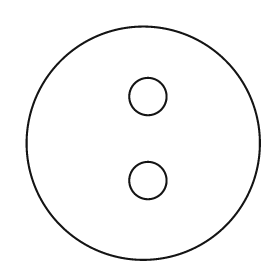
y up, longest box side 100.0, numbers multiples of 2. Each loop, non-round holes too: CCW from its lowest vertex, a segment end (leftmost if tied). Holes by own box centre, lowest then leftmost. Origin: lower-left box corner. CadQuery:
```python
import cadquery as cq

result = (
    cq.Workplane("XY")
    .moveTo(50.0, 50.0)
    .circle(50.0)
    .moveTo(52.0, 34.0)
    .circle(8.0)
    .moveTo(52.0, 70.0)
    .circle(8.0)
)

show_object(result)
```